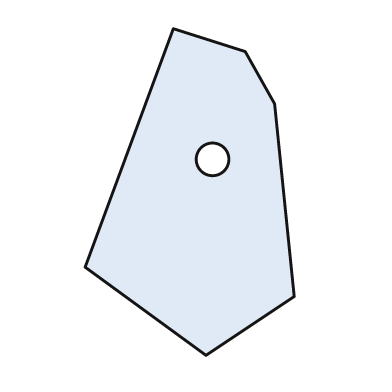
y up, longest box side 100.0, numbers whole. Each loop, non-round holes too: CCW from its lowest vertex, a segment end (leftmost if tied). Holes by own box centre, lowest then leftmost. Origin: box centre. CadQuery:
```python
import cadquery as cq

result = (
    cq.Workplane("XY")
    .moveTo(5.0, -50.0)
    .lineTo(32.0, -32.0)
    .lineTo(26.0, 27.0)
    .lineTo(17.0, 43.0)
    .lineTo(-5.0, 50.0)
    .lineTo(-32.0, -23.0)
    .close()
    .moveTo(7.0, 10.0)
    .circle(5.0)
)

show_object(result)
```